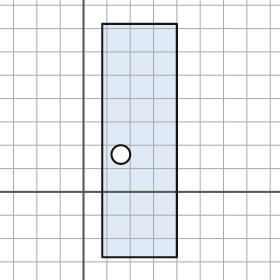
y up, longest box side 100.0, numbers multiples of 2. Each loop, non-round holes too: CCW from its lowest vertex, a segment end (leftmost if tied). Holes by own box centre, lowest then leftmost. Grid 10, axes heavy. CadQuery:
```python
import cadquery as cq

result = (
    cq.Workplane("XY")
    .moveTo(8.0, -28.0)
    .lineTo(40.0, -28.0)
    .lineTo(40.0, 72.0)
    .lineTo(8.0, 72.0)
    .close()
    .moveTo(16.0, 16.0)
    .circle(4.0)
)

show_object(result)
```